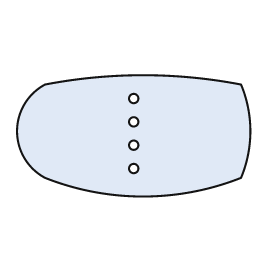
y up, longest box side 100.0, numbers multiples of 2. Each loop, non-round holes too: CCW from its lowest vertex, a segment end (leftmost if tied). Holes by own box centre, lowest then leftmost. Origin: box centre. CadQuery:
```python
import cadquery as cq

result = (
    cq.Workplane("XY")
    .moveTo(-38.0, -18.0)
    .threePointArc((4.0, -26.0), (46.0, -18.0))
    .threePointArc((50.0, 2.0), (46.0, 22.0))
    .threePointArc((4.0, 26.0), (-38.0, 22.0))
    .threePointArc((-50.0, 2.0), (-38.0, -18.0))
    .close()
    .moveTo(0.0, -14.0)
    .circle(2.0)
    .moveTo(0.0, -4.0)
    .circle(2.0)
    .moveTo(0.0, 6.0)
    .circle(2.0)
    .moveTo(0.0, 16.0)
    .circle(2.0)
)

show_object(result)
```